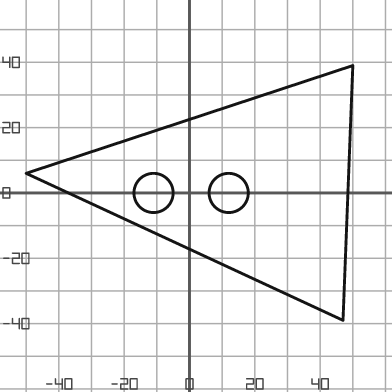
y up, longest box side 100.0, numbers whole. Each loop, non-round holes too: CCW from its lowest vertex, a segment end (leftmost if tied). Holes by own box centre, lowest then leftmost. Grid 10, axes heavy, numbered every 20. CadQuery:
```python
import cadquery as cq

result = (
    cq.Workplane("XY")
    .moveTo(47.0, -39.0)
    .lineTo(50.0, 39.0)
    .lineTo(-50.0, 6.0)
    .close()
    .moveTo(-11.0, 0.0)
    .circle(6.0)
    .moveTo(12.0, 0.0)
    .circle(6.0)
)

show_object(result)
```